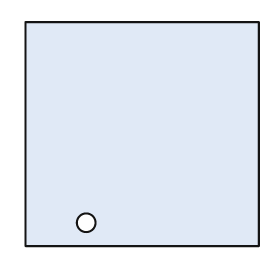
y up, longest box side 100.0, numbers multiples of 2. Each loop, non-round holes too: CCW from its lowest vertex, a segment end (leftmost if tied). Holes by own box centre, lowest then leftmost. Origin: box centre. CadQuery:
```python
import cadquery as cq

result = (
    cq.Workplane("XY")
    .moveTo(-50.0, -48.0)
    .lineTo(50.0, -48.0)
    .lineTo(50.0, 48.0)
    .lineTo(-50.0, 48.0)
    .close()
    .moveTo(-24.0, -38.0)
    .circle(4.0)
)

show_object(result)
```